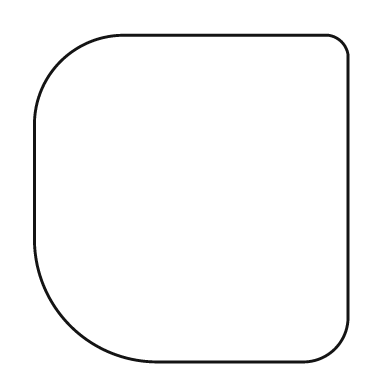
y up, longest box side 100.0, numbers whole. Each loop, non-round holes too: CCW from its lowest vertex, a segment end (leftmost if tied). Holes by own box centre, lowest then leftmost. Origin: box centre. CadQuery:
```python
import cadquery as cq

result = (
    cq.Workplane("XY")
    .moveTo(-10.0, -50.0)
    .lineTo(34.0, -50.0)
    .threePointArc((44.0, -46.0), (48.0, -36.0))
    .lineTo(48.0, 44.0)
    .threePointArc((46.0, 48.0), (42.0, 50.0))
    .lineTo(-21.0, 50.0)
    .threePointArc((-40.0, 42.0), (-48.0, 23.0))
    .lineTo(-48.0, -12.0)
    .threePointArc((-37.0, -39.0), (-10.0, -50.0))
    .close()
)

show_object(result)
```